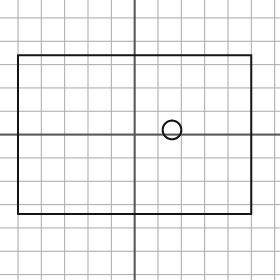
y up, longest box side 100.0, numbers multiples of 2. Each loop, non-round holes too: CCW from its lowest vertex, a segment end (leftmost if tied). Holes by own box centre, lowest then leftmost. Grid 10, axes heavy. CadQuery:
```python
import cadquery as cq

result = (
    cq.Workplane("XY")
    .moveTo(-50.0, -34.0)
    .lineTo(50.0, -34.0)
    .lineTo(50.0, 34.0)
    .lineTo(-50.0, 34.0)
    .close()
    .moveTo(16.0, 2.0)
    .circle(4.0)
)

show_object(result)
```